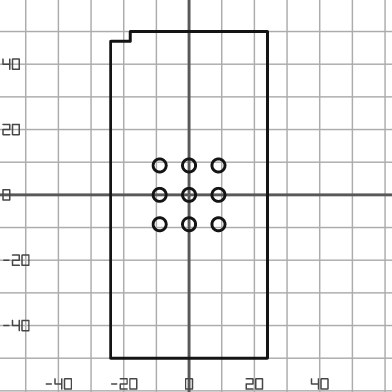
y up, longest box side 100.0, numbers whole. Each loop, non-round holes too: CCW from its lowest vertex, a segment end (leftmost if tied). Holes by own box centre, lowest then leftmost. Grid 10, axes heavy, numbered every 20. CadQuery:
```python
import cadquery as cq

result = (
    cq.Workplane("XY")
    .moveTo(-24.0, -50.0)
    .lineTo(24.0, -50.0)
    .lineTo(24.0, 50.0)
    .lineTo(-18.0, 50.0)
    .lineTo(-18.0, 47.0)
    .lineTo(-24.0, 47.0)
    .close()
    .moveTo(-9.0, -9.0)
    .circle(2.0)
    .moveTo(0.0, -9.0)
    .circle(2.0)
    .moveTo(9.0, -9.0)
    .circle(2.0)
    .moveTo(-9.0, 0.0)
    .circle(2.0)
    .moveTo(0.0, 0.0)
    .circle(2.0)
    .moveTo(9.0, 0.0)
    .circle(2.0)
    .moveTo(-9.0, 9.0)
    .circle(2.0)
    .moveTo(0.0, 9.0)
    .circle(2.0)
    .moveTo(9.0, 9.0)
    .circle(2.0)
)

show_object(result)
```